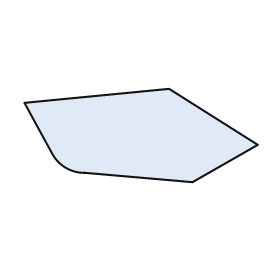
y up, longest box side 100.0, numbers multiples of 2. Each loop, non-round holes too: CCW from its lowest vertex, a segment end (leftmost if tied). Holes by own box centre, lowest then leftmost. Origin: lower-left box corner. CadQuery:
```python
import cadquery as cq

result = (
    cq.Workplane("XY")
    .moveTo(72.0, 0.0)
    .lineTo(100.0, 16.0)
    .lineTo(62.0, 40.0)
    .lineTo(0.0, 34.0)
    .lineTo(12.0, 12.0)
    .threePointArc((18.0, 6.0), (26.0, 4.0))
    .close()
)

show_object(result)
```